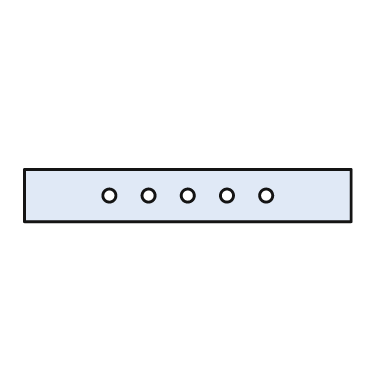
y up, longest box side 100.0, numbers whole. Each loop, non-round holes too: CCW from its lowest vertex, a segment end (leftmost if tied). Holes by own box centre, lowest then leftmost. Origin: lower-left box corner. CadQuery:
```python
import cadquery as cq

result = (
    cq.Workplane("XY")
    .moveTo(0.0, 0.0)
    .lineTo(100.0, 0.0)
    .lineTo(100.0, 16.0)
    .lineTo(0.0, 16.0)
    .close()
    .moveTo(26.0, 8.0)
    .circle(2.0)
    .moveTo(38.0, 8.0)
    .circle(2.0)
    .moveTo(50.0, 8.0)
    .circle(2.0)
    .moveTo(62.0, 8.0)
    .circle(2.0)
    .moveTo(74.0, 8.0)
    .circle(2.0)
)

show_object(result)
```